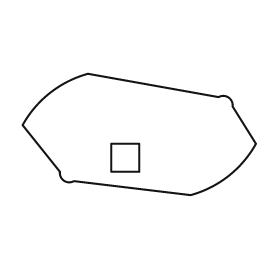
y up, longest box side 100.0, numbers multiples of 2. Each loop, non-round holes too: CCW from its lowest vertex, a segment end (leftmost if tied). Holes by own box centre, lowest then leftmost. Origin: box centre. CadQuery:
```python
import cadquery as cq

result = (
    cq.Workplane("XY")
    .moveTo(22.0, -26.0)
    .threePointArc((38.0, -18.0), (50.0, -4.0))
    .lineTo(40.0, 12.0)
    .threePointArc((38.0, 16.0), (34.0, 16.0))
    .lineTo(-22.0, 26.0)
    .threePointArc((-38.0, 18.0), (-50.0, 4.0))
    .lineTo(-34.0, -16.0)
    .threePointArc((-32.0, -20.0), (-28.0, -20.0))
    .close()
    .moveTo(-12.0, -16.0)
    .lineTo(0.0, -16.0)
    .lineTo(0.0, -4.0)
    .lineTo(-12.0, -4.0)
    .close()
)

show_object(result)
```